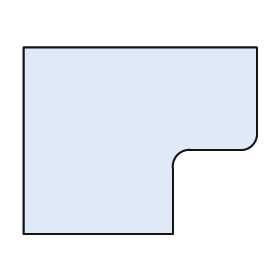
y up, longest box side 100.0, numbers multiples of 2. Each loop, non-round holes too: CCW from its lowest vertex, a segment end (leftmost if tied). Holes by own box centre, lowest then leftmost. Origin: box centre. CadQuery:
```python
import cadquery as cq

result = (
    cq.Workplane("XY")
    .moveTo(-50.0, -40.0)
    .lineTo(14.0, -40.0)
    .lineTo(14.0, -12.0)
    .threePointArc((16.0, -6.0), (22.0, -4.0))
    .lineTo(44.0, -4.0)
    .threePointArc((48.0, -2.0), (50.0, 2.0))
    .lineTo(50.0, 40.0)
    .lineTo(-50.0, 40.0)
    .close()
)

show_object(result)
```